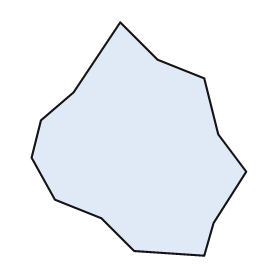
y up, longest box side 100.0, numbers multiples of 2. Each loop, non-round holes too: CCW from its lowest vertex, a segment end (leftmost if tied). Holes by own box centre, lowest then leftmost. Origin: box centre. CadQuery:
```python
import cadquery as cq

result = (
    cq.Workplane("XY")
    .moveTo(28.0, -50.0)
    .lineTo(32.0, -36.0)
    .lineTo(46.0, -14.0)
    .lineTo(34.0, 2.0)
    .lineTo(28.0, 26.0)
    .lineTo(8.0, 34.0)
    .lineTo(-8.0, 50.0)
    .lineTo(-28.0, 20.0)
    .lineTo(-42.0, 8.0)
    .lineTo(-46.0, -8.0)
    .lineTo(-36.0, -26.0)
    .lineTo(-16.0, -34.0)
    .lineTo(-2.0, -48.0)
    .close()
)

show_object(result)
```